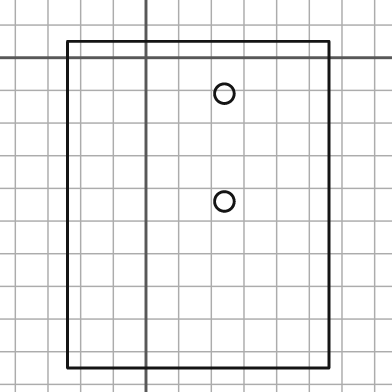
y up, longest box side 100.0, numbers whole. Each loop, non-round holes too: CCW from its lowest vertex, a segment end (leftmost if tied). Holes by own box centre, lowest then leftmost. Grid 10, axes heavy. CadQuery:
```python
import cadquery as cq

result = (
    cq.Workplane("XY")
    .moveTo(-24.0, -95.0)
    .lineTo(56.0, -95.0)
    .lineTo(56.0, 5.0)
    .lineTo(-24.0, 5.0)
    .close()
    .moveTo(24.0, -44.0)
    .circle(3.0)
    .moveTo(24.0, -11.0)
    .circle(3.0)
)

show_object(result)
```